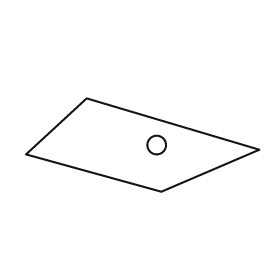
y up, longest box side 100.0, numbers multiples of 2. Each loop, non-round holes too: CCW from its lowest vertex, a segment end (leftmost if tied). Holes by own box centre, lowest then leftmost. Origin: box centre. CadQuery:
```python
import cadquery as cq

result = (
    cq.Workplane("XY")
    .moveTo(8.0, -20.0)
    .lineTo(50.0, -2.0)
    .lineTo(-24.0, 20.0)
    .lineTo(-50.0, -4.0)
    .close()
    .moveTo(6.0, 0.0)
    .circle(4.0)
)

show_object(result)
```